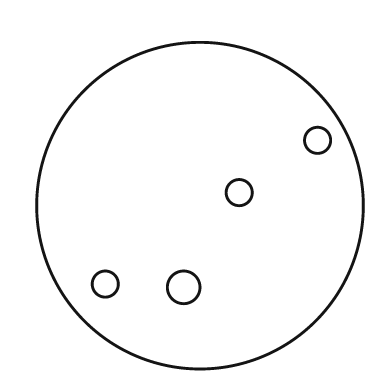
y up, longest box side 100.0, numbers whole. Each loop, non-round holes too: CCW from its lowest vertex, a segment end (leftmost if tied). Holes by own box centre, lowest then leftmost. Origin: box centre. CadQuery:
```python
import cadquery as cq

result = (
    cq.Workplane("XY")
    .moveTo(0.0, 0.0)
    .circle(50.0)
    .moveTo(-5.0, -25.0)
    .circle(5.0)
    .moveTo(-29.0, -24.0)
    .circle(4.0)
    .moveTo(12.0, 4.0)
    .circle(4.0)
    .moveTo(36.0, 20.0)
    .circle(4.0)
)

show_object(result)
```